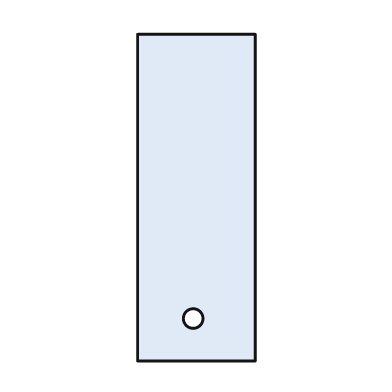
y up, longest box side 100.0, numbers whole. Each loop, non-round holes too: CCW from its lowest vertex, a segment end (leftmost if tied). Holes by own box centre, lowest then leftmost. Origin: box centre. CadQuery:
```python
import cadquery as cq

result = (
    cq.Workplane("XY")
    .moveTo(-18.0, -50.0)
    .lineTo(18.0, -50.0)
    .lineTo(18.0, 50.0)
    .lineTo(-18.0, 50.0)
    .close()
    .moveTo(-1.0, -37.0)
    .circle(3.0)
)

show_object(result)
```